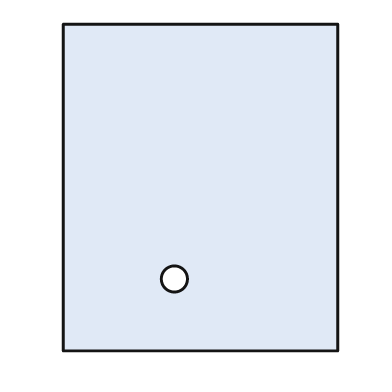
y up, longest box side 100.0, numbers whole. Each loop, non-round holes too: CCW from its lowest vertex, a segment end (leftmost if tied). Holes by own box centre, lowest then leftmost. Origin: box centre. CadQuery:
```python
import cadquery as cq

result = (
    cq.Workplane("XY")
    .moveTo(-42.0, -50.0)
    .lineTo(42.0, -50.0)
    .lineTo(42.0, 50.0)
    .lineTo(-42.0, 50.0)
    .close()
    .moveTo(-8.0, -28.0)
    .circle(4.0)
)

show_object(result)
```